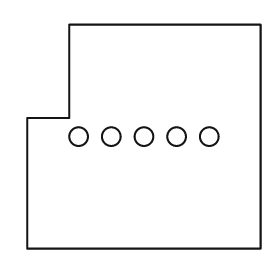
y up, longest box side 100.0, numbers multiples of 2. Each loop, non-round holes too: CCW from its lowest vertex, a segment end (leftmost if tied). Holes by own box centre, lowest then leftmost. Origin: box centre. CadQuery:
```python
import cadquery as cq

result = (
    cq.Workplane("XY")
    .moveTo(-50.0, -48.0)
    .lineTo(50.0, -48.0)
    .lineTo(50.0, 48.0)
    .lineTo(-32.0, 48.0)
    .lineTo(-32.0, 8.0)
    .lineTo(-50.0, 8.0)
    .close()
    .moveTo(-28.0, 0.0)
    .circle(4.0)
    .moveTo(-14.0, 0.0)
    .circle(4.0)
    .moveTo(0.0, 0.0)
    .circle(4.0)
    .moveTo(14.0, 0.0)
    .circle(4.0)
    .moveTo(28.0, 0.0)
    .circle(4.0)
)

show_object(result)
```